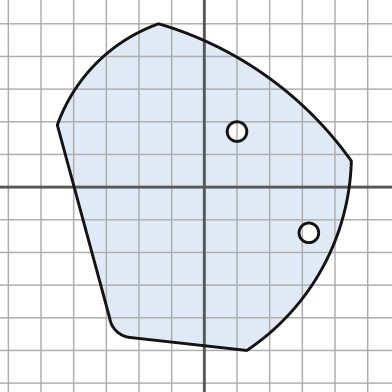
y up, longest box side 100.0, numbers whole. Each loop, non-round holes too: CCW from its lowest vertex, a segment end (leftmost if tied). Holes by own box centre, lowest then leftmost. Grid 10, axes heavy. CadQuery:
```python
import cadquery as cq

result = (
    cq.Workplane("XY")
    .moveTo(13.0, -50.0)
    .threePointArc((36.0, -25.0), (45.0, 8.0))
    .threePointArc((19.0, 34.0), (-14.0, 50.0))
    .threePointArc((-33.0, 38.0), (-45.0, 19.0))
    .lineTo(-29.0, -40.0)
    .threePointArc((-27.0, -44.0), (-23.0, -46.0))
    .close()
    .moveTo(32.0, -14.0)
    .circle(3.0)
    .moveTo(10.0, 17.0)
    .circle(3.0)
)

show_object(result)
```